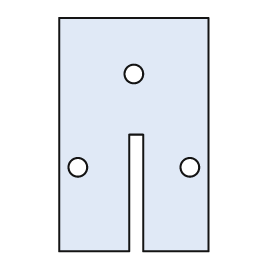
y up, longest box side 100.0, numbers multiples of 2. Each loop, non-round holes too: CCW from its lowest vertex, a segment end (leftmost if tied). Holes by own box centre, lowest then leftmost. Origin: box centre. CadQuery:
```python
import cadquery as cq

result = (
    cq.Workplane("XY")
    .moveTo(-32.0, -50.0)
    .lineTo(-2.0, -50.0)
    .lineTo(-2.0, 0.0)
    .lineTo(4.0, 0.0)
    .lineTo(4.0, -50.0)
    .lineTo(32.0, -50.0)
    .lineTo(32.0, 50.0)
    .lineTo(-32.0, 50.0)
    .close()
    .moveTo(-24.0, -14.0)
    .circle(4.0)
    .moveTo(24.0, -14.0)
    .circle(4.0)
    .moveTo(0.0, 26.0)
    .circle(4.0)
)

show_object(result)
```